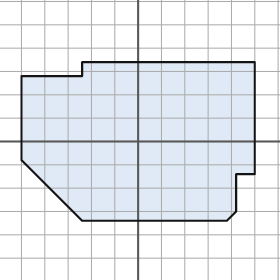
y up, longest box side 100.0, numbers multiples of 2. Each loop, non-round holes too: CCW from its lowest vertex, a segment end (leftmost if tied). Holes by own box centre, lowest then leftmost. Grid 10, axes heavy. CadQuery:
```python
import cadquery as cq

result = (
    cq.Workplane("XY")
    .moveTo(-24.0, -34.0)
    .lineTo(38.0, -34.0)
    .lineTo(42.0, -30.0)
    .lineTo(42.0, -14.0)
    .lineTo(50.0, -14.0)
    .lineTo(50.0, 34.0)
    .lineTo(-24.0, 34.0)
    .lineTo(-24.0, 28.0)
    .lineTo(-50.0, 28.0)
    .lineTo(-50.0, -8.0)
    .close()
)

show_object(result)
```